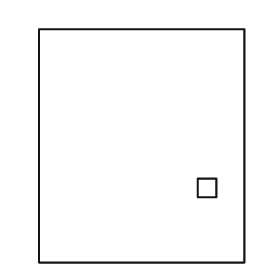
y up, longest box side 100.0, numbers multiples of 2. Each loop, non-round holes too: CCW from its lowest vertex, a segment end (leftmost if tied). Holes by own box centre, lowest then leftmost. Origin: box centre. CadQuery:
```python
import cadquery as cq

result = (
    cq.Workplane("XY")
    .moveTo(-44.0, -50.0)
    .lineTo(44.0, -50.0)
    .lineTo(44.0, 50.0)
    .lineTo(-44.0, 50.0)
    .close()
    .moveTo(24.0, -22.0)
    .lineTo(32.0, -22.0)
    .lineTo(32.0, -14.0)
    .lineTo(24.0, -14.0)
    .close()
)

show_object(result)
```